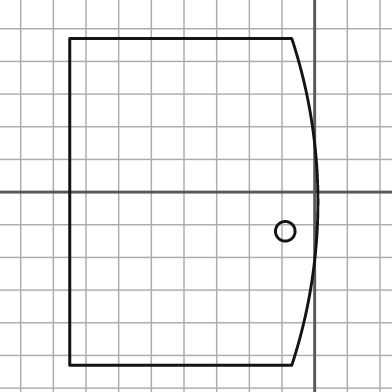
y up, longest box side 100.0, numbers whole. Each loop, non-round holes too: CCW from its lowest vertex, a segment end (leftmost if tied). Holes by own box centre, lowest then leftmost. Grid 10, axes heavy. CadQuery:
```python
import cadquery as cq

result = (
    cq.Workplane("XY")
    .moveTo(-75.0, -53.0)
    .lineTo(-7.0, -53.0)
    .threePointArc((1.0, -3.0), (-7.0, 47.0))
    .lineTo(-75.0, 47.0)
    .close()
    .moveTo(-9.0, -12.0)
    .circle(3.0)
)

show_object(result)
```